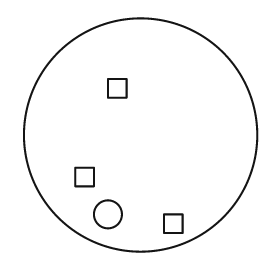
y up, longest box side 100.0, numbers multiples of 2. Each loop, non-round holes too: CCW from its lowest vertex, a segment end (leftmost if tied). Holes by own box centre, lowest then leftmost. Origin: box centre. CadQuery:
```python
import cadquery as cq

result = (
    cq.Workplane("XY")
    .moveTo(0.0, 0.0)
    .circle(50.0)
    .moveTo(10.0, -42.0)
    .lineTo(18.0, -42.0)
    .lineTo(18.0, -34.0)
    .lineTo(10.0, -34.0)
    .close()
    .moveTo(-14.0, -34.0)
    .circle(6.0)
    .moveTo(-28.0, -22.0)
    .lineTo(-20.0, -22.0)
    .lineTo(-20.0, -14.0)
    .lineTo(-28.0, -14.0)
    .close()
    .moveTo(-14.0, 16.0)
    .lineTo(-6.0, 16.0)
    .lineTo(-6.0, 24.0)
    .lineTo(-14.0, 24.0)
    .close()
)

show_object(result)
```